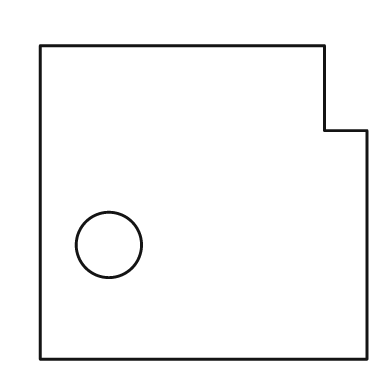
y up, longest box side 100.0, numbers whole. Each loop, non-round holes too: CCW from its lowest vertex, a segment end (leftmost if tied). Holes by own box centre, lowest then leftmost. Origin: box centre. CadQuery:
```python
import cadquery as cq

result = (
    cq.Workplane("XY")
    .moveTo(-50.0, -48.0)
    .lineTo(50.0, -48.0)
    .lineTo(50.0, 22.0)
    .lineTo(37.0, 22.0)
    .lineTo(37.0, 48.0)
    .lineTo(-50.0, 48.0)
    .close()
    .moveTo(-29.0, -13.0)
    .circle(10.0)
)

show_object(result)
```